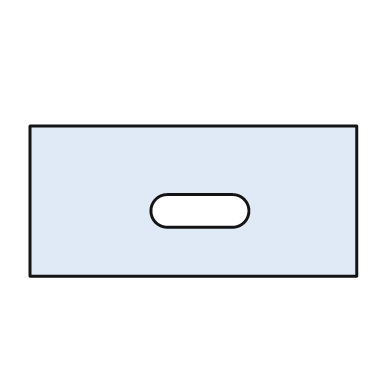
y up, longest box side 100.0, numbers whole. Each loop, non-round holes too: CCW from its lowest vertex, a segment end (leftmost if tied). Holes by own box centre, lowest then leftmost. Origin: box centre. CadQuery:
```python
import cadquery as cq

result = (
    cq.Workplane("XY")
    .moveTo(-50.0, -23.0)
    .lineTo(50.0, -23.0)
    .lineTo(50.0, 23.0)
    .lineTo(-50.0, 23.0)
    .close()
    .moveTo(-8.0, -8.0)
    .lineTo(12.0, -8.0)
    .threePointArc((17.0, -3.0), (12.0, 2.0))
    .lineTo(-8.0, 2.0)
    .threePointArc((-13.0, -3.0), (-8.0, -8.0))
    .close()
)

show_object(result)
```